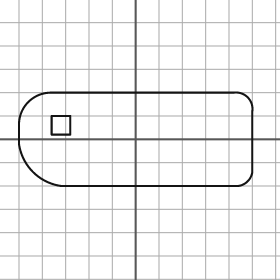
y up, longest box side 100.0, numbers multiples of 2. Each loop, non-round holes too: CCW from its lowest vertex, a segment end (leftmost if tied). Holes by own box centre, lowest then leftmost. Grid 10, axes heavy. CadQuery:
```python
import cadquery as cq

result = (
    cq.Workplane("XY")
    .moveTo(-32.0, -20.0)
    .lineTo(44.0, -20.0)
    .threePointArc((48.0, -18.0), (50.0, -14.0))
    .lineTo(50.0, 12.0)
    .threePointArc((48.0, 18.0), (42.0, 20.0))
    .lineTo(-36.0, 20.0)
    .threePointArc((-46.0, 16.0), (-50.0, 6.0))
    .lineTo(-50.0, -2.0)
    .threePointArc((-44.0, -14.0), (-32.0, -20.0))
    .close()
    .moveTo(-36.0, 2.0)
    .lineTo(-28.0, 2.0)
    .lineTo(-28.0, 10.0)
    .lineTo(-36.0, 10.0)
    .close()
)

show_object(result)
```